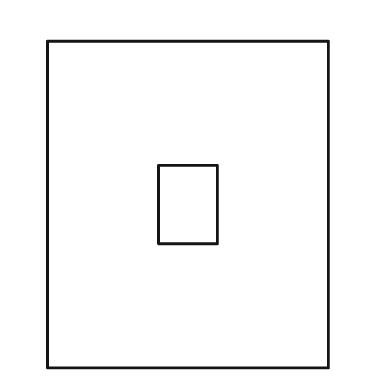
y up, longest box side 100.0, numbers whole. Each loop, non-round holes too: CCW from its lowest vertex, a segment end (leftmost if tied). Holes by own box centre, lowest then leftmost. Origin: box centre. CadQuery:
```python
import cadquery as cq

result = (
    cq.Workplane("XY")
    .moveTo(-43.0, -50.0)
    .lineTo(43.0, -50.0)
    .lineTo(43.0, 50.0)
    .lineTo(-43.0, 50.0)
    .close()
    .moveTo(-9.0, -12.0)
    .lineTo(9.0, -12.0)
    .lineTo(9.0, 12.0)
    .lineTo(-9.0, 12.0)
    .close()
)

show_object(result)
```